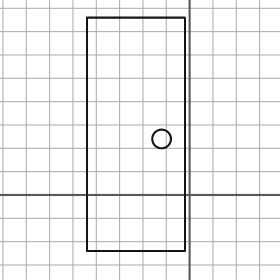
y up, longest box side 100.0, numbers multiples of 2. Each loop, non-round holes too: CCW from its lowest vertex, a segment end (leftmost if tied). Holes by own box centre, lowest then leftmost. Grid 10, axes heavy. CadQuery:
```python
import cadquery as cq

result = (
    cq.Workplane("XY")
    .moveTo(-44.0, -24.0)
    .lineTo(-2.0, -24.0)
    .lineTo(-2.0, 76.0)
    .lineTo(-44.0, 76.0)
    .close()
    .moveTo(-12.0, 24.0)
    .circle(4.0)
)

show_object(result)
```